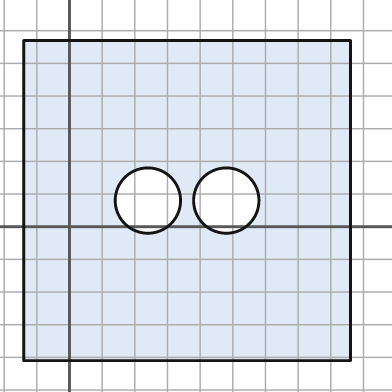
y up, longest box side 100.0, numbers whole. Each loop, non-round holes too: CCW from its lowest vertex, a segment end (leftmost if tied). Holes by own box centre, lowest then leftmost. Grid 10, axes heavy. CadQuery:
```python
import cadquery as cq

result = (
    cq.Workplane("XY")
    .moveTo(-14.0, -41.0)
    .lineTo(86.0, -41.0)
    .lineTo(86.0, 57.0)
    .lineTo(-14.0, 57.0)
    .close()
    .moveTo(24.0, 8.0)
    .circle(10.0)
    .moveTo(48.0, 8.0)
    .circle(10.0)
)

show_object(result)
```